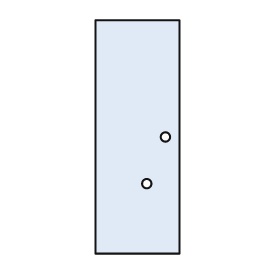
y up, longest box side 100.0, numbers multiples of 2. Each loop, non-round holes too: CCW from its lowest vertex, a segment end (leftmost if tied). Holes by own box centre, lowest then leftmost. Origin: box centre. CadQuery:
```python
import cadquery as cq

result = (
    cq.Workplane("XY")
    .moveTo(-18.0, -50.0)
    .lineTo(18.0, -50.0)
    .lineTo(18.0, 50.0)
    .lineTo(-18.0, 50.0)
    .close()
    .moveTo(4.0, -20.0)
    .circle(2.0)
    .moveTo(12.0, 0.0)
    .circle(2.0)
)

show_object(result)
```